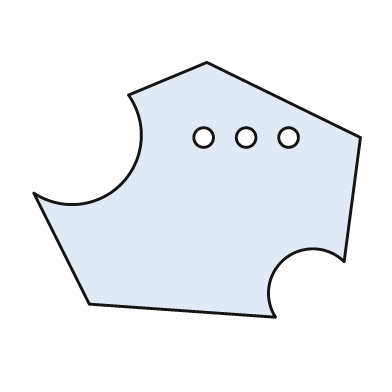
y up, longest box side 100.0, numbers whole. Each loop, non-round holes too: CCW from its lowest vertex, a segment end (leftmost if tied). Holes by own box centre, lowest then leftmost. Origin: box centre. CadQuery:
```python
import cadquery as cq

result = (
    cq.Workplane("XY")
    .moveTo(24.0, -39.0)
    .threePointArc((27.0, -21.0), (45.0, -22.0))
    .lineTo(50.0, 16.0)
    .lineTo(3.0, 39.0)
    .lineTo(-21.0, 29.0)
    .threePointArc((-23.0, 2.0), (-50.0, -1.0))
    .lineTo(-33.0, -35.0)
    .close()
    .moveTo(2.0, 16.0)
    .circle(3.0)
    .moveTo(15.0, 16.0)
    .circle(3.0)
    .moveTo(28.0, 16.0)
    .circle(3.0)
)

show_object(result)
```